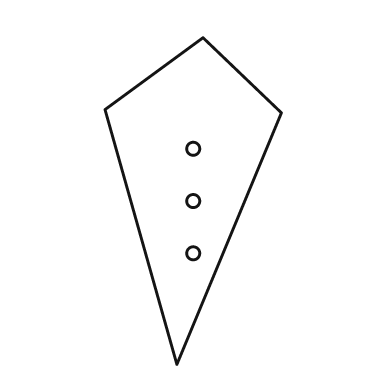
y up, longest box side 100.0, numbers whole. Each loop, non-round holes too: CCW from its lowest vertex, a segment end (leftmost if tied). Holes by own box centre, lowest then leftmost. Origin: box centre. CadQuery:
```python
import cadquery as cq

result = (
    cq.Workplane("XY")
    .moveTo(-5.0, -50.0)
    .lineTo(27.0, 27.0)
    .lineTo(3.0, 50.0)
    .lineTo(-27.0, 28.0)
    .close()
    .moveTo(0.0, -16.0)
    .circle(2.0)
    .moveTo(0.0, 0.0)
    .circle(2.0)
    .moveTo(0.0, 16.0)
    .circle(2.0)
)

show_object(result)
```